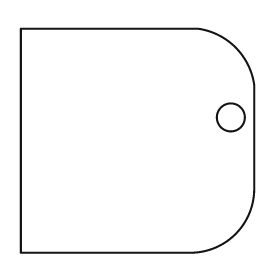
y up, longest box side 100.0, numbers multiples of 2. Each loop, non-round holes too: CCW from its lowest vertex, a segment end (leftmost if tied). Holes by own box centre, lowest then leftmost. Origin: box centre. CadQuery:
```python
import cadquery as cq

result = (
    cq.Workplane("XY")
    .moveTo(-50.0, -48.0)
    .lineTo(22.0, -48.0)
    .threePointArc((42.0, -40.0), (50.0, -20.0))
    .lineTo(50.0, 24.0)
    .threePointArc((42.0, 40.0), (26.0, 48.0))
    .lineTo(-50.0, 48.0)
    .close()
    .moveTo(40.0, 10.0)
    .circle(6.0)
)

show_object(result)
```